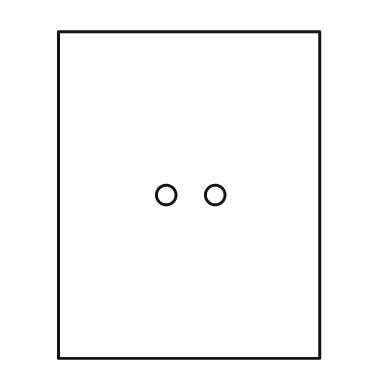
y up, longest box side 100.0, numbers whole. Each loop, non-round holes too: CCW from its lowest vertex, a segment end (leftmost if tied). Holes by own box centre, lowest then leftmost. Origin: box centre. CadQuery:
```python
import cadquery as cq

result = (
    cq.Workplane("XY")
    .moveTo(-40.0, -50.0)
    .lineTo(40.0, -50.0)
    .lineTo(40.0, 50.0)
    .lineTo(-40.0, 50.0)
    .close()
    .moveTo(-7.0, 0.0)
    .circle(3.0)
    .moveTo(8.0, 0.0)
    .circle(3.0)
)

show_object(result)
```